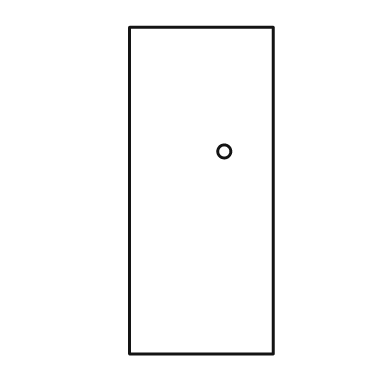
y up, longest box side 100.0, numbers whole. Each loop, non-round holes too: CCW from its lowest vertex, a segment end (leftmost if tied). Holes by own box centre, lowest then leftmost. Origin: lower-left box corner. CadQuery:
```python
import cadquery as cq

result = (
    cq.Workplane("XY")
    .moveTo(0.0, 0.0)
    .lineTo(44.0, 0.0)
    .lineTo(44.0, 100.0)
    .lineTo(0.0, 100.0)
    .close()
    .moveTo(29.0, 62.0)
    .circle(2.0)
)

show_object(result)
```